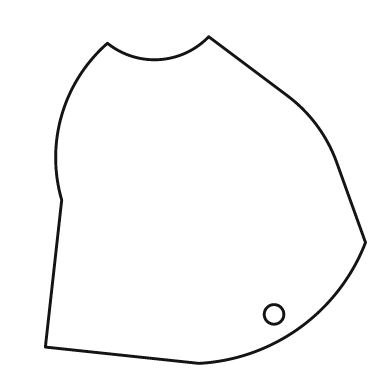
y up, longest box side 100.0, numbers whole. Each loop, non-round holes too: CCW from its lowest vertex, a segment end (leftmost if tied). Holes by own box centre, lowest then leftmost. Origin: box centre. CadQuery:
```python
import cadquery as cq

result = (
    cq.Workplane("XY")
    .moveTo(-2.0, -50.0)
    .threePointArc((29.0, -39.0), (49.0, -13.0))
    .lineTo(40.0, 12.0)
    .threePointArc((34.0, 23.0), (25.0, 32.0))
    .lineTo(1.0, 50.0)
    .threePointArc((-14.0, 43.0), (-30.0, 48.0))
    .threePointArc((-44.0, 26.0), (-44.0, 0.0))
    .lineTo(-49.0, -45.0)
    .close()
    .moveTo(21.0, -35.0)
    .circle(3.0)
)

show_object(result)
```